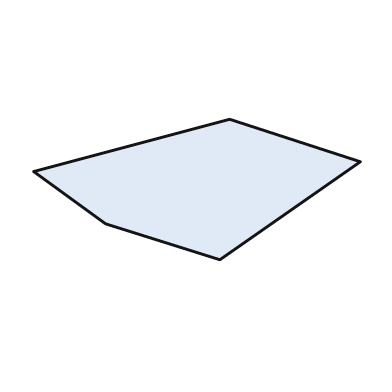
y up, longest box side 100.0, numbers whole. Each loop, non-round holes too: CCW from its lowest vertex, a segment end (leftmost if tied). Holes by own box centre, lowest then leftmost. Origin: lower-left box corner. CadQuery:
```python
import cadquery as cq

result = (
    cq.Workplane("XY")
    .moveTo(57.0, 0.0)
    .lineTo(100.0, 30.0)
    .lineTo(60.0, 43.0)
    .lineTo(0.0, 27.0)
    .lineTo(22.0, 11.0)
    .close()
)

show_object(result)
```